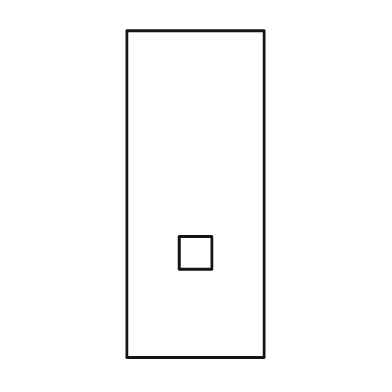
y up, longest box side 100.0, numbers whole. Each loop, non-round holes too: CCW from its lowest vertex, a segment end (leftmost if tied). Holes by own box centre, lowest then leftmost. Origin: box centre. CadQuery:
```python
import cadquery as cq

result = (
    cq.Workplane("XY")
    .moveTo(-21.0, -50.0)
    .lineTo(21.0, -50.0)
    .lineTo(21.0, 50.0)
    .lineTo(-21.0, 50.0)
    .close()
    .moveTo(-5.0, -23.0)
    .lineTo(5.0, -23.0)
    .lineTo(5.0, -13.0)
    .lineTo(-5.0, -13.0)
    .close()
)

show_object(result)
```